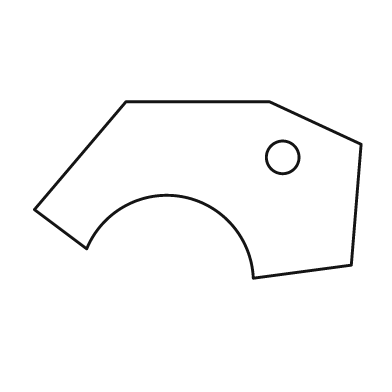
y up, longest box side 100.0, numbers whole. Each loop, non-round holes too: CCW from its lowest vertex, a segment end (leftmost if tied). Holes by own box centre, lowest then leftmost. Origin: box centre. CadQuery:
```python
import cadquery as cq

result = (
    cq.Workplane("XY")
    .moveTo(17.0, -27.0)
    .lineTo(47.0, -23.0)
    .lineTo(50.0, 14.0)
    .lineTo(22.0, 27.0)
    .lineTo(-22.0, 27.0)
    .lineTo(-50.0, -6.0)
    .lineTo(-34.0, -18.0)
    .threePointArc((-5.0, -2.0), (17.0, -27.0))
    .close()
    .moveTo(26.0, 10.0)
    .circle(5.0)
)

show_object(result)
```